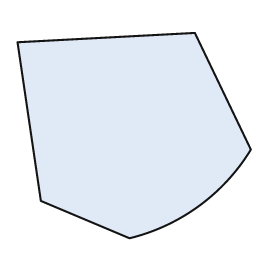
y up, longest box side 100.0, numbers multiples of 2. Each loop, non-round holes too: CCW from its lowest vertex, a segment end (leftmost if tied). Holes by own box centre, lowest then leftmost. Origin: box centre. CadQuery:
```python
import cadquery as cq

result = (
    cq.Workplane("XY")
    .moveTo(-2.0, -44.0)
    .threePointArc((28.0, -30.0), (50.0, -6.0))
    .lineTo(26.0, 44.0)
    .lineTo(-50.0, 40.0)
    .lineTo(-40.0, -28.0)
    .close()
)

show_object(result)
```